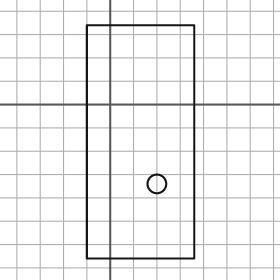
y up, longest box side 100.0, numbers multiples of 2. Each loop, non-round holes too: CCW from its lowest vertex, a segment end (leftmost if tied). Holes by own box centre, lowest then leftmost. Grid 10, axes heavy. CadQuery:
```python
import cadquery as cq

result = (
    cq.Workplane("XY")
    .moveTo(-10.0, -66.0)
    .lineTo(36.0, -66.0)
    .lineTo(36.0, 34.0)
    .lineTo(-10.0, 34.0)
    .close()
    .moveTo(20.0, -34.0)
    .circle(4.0)
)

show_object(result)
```